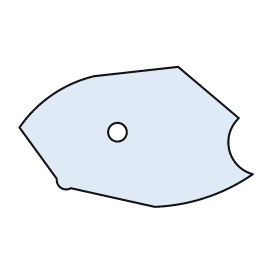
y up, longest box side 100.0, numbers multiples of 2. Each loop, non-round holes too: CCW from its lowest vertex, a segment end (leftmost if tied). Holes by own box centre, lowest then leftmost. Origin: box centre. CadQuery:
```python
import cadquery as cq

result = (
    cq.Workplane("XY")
    .moveTo(8.0, -30.0)
    .threePointArc((30.0, -26.0), (50.0, -16.0))
    .threePointArc((40.0, -6.0), (44.0, 8.0))
    .lineTo(18.0, 30.0)
    .lineTo(-18.0, 26.0)
    .threePointArc((-36.0, 18.0), (-50.0, 4.0))
    .lineTo(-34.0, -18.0)
    .threePointArc((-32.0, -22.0), (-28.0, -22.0))
    .close()
    .moveTo(-8.0, 2.0)
    .circle(4.0)
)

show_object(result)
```